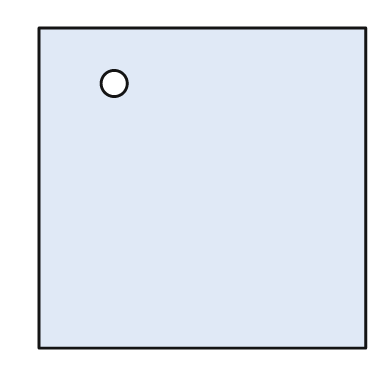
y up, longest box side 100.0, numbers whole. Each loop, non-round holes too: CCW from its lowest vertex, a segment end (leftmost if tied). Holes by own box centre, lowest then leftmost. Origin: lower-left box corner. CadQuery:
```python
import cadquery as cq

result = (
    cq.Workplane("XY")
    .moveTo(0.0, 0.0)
    .lineTo(100.0, 0.0)
    .lineTo(100.0, 98.0)
    .lineTo(0.0, 98.0)
    .close()
    .moveTo(23.0, 81.0)
    .circle(4.0)
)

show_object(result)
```